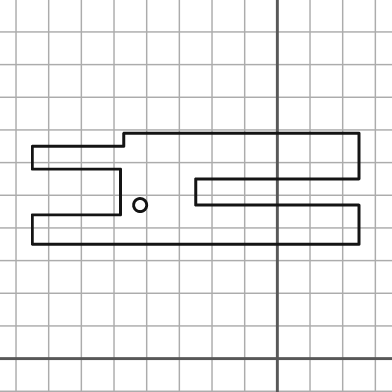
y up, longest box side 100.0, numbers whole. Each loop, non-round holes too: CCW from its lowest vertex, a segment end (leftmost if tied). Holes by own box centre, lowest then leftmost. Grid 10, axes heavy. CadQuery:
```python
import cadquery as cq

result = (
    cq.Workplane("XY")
    .moveTo(-75.0, 35.0)
    .lineTo(25.0, 35.0)
    .lineTo(25.0, 47.0)
    .lineTo(-25.0, 47.0)
    .lineTo(-25.0, 55.0)
    .lineTo(25.0, 55.0)
    .lineTo(25.0, 69.0)
    .lineTo(-47.0, 69.0)
    .lineTo(-47.0, 65.0)
    .lineTo(-75.0, 65.0)
    .lineTo(-75.0, 58.0)
    .lineTo(-48.0, 58.0)
    .lineTo(-48.0, 44.0)
    .lineTo(-75.0, 44.0)
    .close()
    .moveTo(-42.0, 47.0)
    .circle(2.0)
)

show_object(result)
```